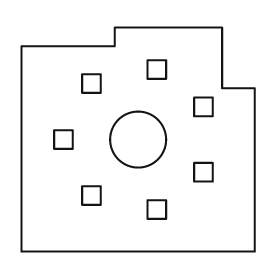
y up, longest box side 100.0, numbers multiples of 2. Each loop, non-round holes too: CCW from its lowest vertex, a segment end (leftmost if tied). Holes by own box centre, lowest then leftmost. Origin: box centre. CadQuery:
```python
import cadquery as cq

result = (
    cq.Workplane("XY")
    .moveTo(-50.0, -48.0)
    .lineTo(50.0, -48.0)
    .lineTo(50.0, 22.0)
    .lineTo(36.0, 22.0)
    .lineTo(36.0, 48.0)
    .lineTo(-10.0, 48.0)
    .lineTo(-10.0, 40.0)
    .lineTo(-50.0, 40.0)
    .close()
    .moveTo(4.0, -34.0)
    .lineTo(12.0, -34.0)
    .lineTo(12.0, -26.0)
    .lineTo(4.0, -26.0)
    .close()
    .moveTo(-24.0, -28.0)
    .lineTo(-16.0, -28.0)
    .lineTo(-16.0, -20.0)
    .lineTo(-24.0, -20.0)
    .close()
    .moveTo(24.0, -18.0)
    .lineTo(32.0, -18.0)
    .lineTo(32.0, -10.0)
    .lineTo(24.0, -10.0)
    .close()
    .moveTo(-36.0, -4.0)
    .lineTo(-28.0, -4.0)
    .lineTo(-28.0, 4.0)
    .lineTo(-36.0, 4.0)
    .close()
    .moveTo(0.0, 0.0)
    .circle(12.0)
    .moveTo(24.0, 10.0)
    .lineTo(32.0, 10.0)
    .lineTo(32.0, 18.0)
    .lineTo(24.0, 18.0)
    .close()
    .moveTo(-24.0, 20.0)
    .lineTo(-16.0, 20.0)
    .lineTo(-16.0, 28.0)
    .lineTo(-24.0, 28.0)
    .close()
    .moveTo(4.0, 26.0)
    .lineTo(12.0, 26.0)
    .lineTo(12.0, 34.0)
    .lineTo(4.0, 34.0)
    .close()
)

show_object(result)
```